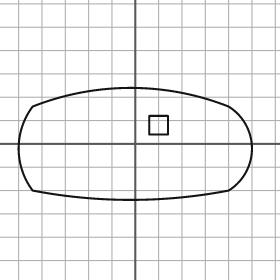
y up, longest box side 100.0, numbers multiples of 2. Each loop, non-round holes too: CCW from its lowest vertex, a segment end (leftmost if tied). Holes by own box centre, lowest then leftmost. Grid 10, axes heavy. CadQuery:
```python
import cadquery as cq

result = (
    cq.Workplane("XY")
    .moveTo(-44.0, -20.0)
    .threePointArc((-2.0, -24.0), (40.0, -20.0))
    .threePointArc((50.0, -2.0), (40.0, 16.0))
    .threePointArc((-2.0, 24.0), (-44.0, 16.0))
    .threePointArc((-50.0, -2.0), (-44.0, -20.0))
    .close()
    .moveTo(6.0, 4.0)
    .lineTo(14.0, 4.0)
    .lineTo(14.0, 12.0)
    .lineTo(6.0, 12.0)
    .close()
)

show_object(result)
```